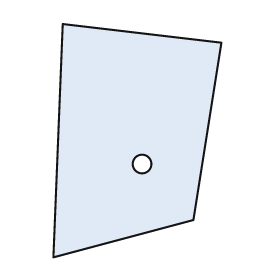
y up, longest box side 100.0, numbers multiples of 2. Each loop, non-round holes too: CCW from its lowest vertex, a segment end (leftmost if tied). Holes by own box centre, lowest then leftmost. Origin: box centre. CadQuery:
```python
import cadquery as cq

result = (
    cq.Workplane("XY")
    .moveTo(-36.0, -50.0)
    .lineTo(24.0, -34.0)
    .lineTo(36.0, 42.0)
    .lineTo(-32.0, 50.0)
    .close()
    .moveTo(2.0, -10.0)
    .circle(4.0)
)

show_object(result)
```